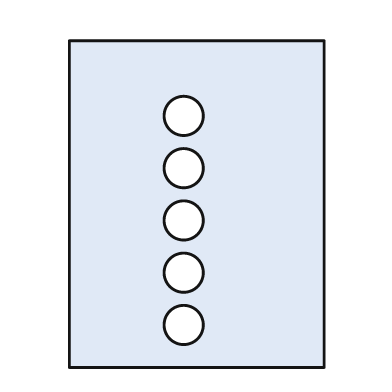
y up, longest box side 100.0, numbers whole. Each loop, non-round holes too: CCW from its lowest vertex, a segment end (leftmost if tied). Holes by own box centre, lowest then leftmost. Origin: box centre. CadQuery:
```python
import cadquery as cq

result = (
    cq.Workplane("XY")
    .moveTo(-39.0, -50.0)
    .lineTo(39.0, -50.0)
    .lineTo(39.0, 50.0)
    .lineTo(-39.0, 50.0)
    .close()
    .moveTo(-4.0, -37.0)
    .circle(6.0)
    .moveTo(-4.0, -21.0)
    .circle(6.0)
    .moveTo(-4.0, -5.0)
    .circle(6.0)
    .moveTo(-4.0, 11.0)
    .circle(6.0)
    .moveTo(-4.0, 27.0)
    .circle(6.0)
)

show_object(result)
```